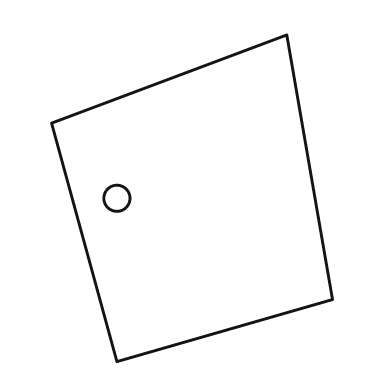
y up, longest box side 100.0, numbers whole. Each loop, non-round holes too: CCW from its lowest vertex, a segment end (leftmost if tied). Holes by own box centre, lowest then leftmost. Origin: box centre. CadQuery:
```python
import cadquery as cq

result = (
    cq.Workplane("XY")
    .moveTo(-23.0, -50.0)
    .lineTo(43.0, -31.0)
    .lineTo(29.0, 50.0)
    .lineTo(-43.0, 23.0)
    .close()
    .moveTo(-23.0, 0.0)
    .circle(4.0)
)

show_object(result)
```